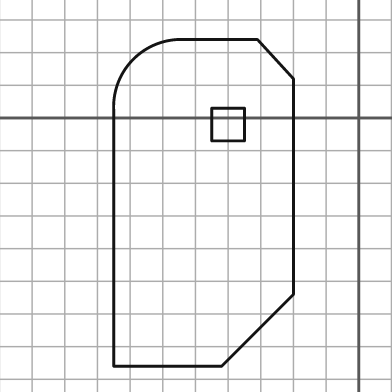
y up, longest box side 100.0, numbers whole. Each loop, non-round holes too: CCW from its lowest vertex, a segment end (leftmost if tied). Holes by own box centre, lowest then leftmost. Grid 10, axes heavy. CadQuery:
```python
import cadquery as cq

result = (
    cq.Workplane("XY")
    .moveTo(-75.0, -76.0)
    .lineTo(-42.0, -76.0)
    .lineTo(-20.0, -54.0)
    .lineTo(-20.0, 12.0)
    .lineTo(-31.0, 24.0)
    .lineTo(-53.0, 24.0)
    .threePointArc((-69.0, 18.0), (-75.0, 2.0))
    .close()
    .moveTo(-45.0, -7.0)
    .lineTo(-35.0, -7.0)
    .lineTo(-35.0, 3.0)
    .lineTo(-45.0, 3.0)
    .close()
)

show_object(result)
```